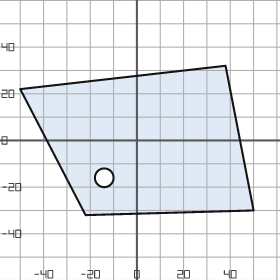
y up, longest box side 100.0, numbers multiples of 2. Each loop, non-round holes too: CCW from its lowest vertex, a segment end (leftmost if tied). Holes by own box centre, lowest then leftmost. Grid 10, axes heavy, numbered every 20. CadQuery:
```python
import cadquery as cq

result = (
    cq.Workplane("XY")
    .moveTo(-22.0, -32.0)
    .lineTo(50.0, -30.0)
    .lineTo(38.0, 32.0)
    .lineTo(-50.0, 22.0)
    .close()
    .moveTo(-14.0, -16.0)
    .circle(4.0)
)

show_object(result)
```